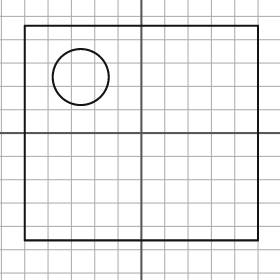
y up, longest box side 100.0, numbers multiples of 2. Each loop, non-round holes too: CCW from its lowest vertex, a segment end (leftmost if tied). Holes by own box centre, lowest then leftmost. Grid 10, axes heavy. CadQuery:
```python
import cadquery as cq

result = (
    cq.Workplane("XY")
    .moveTo(-50.0, -46.0)
    .lineTo(50.0, -46.0)
    .lineTo(50.0, 46.0)
    .lineTo(-50.0, 46.0)
    .close()
    .moveTo(-26.0, 24.0)
    .circle(12.0)
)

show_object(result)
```